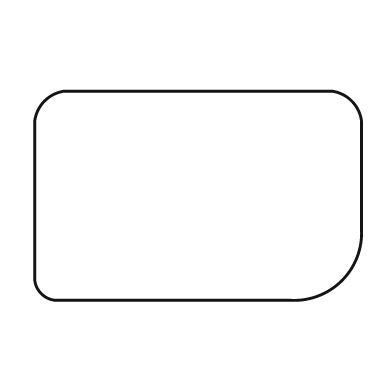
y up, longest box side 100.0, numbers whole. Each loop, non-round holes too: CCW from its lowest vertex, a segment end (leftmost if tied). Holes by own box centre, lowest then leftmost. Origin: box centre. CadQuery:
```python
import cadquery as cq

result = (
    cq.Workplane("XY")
    .moveTo(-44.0, -32.0)
    .lineTo(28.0, -32.0)
    .threePointArc((44.0, -26.0), (50.0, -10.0))
    .lineTo(50.0, 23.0)
    .threePointArc((47.0, 29.0), (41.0, 32.0))
    .lineTo(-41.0, 32.0)
    .threePointArc((-47.0, 29.0), (-50.0, 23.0))
    .lineTo(-50.0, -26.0)
    .threePointArc((-48.0, -30.0), (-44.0, -32.0))
    .close()
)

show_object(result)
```